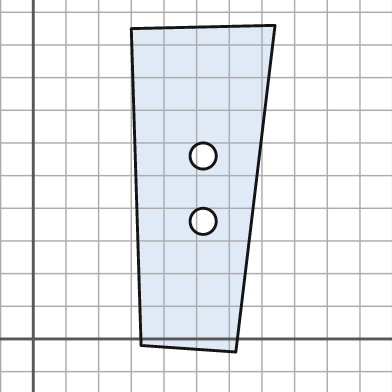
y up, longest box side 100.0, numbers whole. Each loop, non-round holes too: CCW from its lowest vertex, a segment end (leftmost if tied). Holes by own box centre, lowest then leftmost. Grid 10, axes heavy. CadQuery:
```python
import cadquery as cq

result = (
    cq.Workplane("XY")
    .moveTo(62.0, -4.0)
    .lineTo(74.0, 96.0)
    .lineTo(30.0, 95.0)
    .lineTo(33.0, -2.0)
    .close()
    .moveTo(52.0, 36.0)
    .circle(4.0)
    .moveTo(52.0, 56.0)
    .circle(4.0)
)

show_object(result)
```